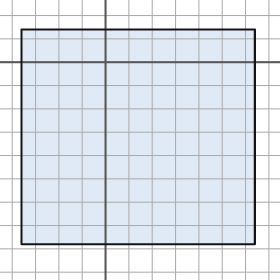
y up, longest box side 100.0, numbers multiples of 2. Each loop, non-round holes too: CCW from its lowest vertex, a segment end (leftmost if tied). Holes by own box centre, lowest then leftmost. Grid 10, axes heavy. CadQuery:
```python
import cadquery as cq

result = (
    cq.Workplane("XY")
    .moveTo(-36.0, -78.0)
    .lineTo(64.0, -78.0)
    .lineTo(64.0, 14.0)
    .lineTo(-36.0, 14.0)
    .close()
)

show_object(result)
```